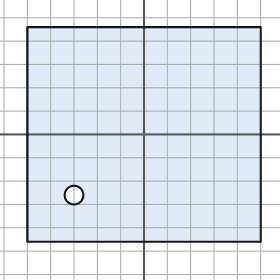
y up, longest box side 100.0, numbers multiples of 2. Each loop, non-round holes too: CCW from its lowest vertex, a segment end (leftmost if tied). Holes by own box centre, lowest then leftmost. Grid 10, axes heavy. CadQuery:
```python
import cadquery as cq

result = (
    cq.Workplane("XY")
    .moveTo(-50.0, -46.0)
    .lineTo(50.0, -46.0)
    .lineTo(50.0, 46.0)
    .lineTo(-50.0, 46.0)
    .close()
    .moveTo(-30.0, -26.0)
    .circle(4.0)
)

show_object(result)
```